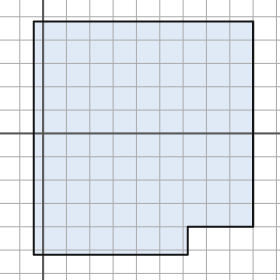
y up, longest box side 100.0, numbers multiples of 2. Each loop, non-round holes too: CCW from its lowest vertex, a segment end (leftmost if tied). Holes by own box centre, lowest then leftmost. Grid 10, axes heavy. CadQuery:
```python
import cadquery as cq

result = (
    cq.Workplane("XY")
    .moveTo(-4.0, -52.0)
    .lineTo(62.0, -52.0)
    .lineTo(62.0, -40.0)
    .lineTo(90.0, -40.0)
    .lineTo(90.0, 48.0)
    .lineTo(-4.0, 48.0)
    .close()
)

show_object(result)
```